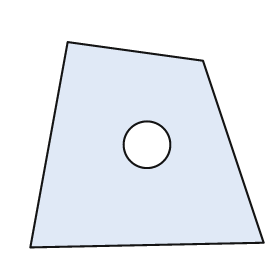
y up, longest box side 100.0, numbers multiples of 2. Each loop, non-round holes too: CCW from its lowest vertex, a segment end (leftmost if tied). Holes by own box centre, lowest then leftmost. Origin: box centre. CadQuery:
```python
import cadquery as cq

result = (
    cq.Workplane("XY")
    .moveTo(-50.0, -44.0)
    .lineTo(50.0, -42.0)
    .lineTo(24.0, 36.0)
    .lineTo(-34.0, 44.0)
    .close()
    .moveTo(0.0, 0.0)
    .circle(10.0)
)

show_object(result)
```